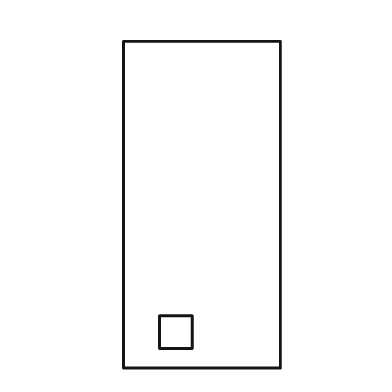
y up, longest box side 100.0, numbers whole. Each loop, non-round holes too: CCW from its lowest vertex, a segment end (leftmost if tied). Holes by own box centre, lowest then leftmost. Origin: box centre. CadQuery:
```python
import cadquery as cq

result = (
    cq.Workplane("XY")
    .moveTo(-24.0, -50.0)
    .lineTo(24.0, -50.0)
    .lineTo(24.0, 50.0)
    .lineTo(-24.0, 50.0)
    .close()
    .moveTo(-13.0, -44.0)
    .lineTo(-3.0, -44.0)
    .lineTo(-3.0, -34.0)
    .lineTo(-13.0, -34.0)
    .close()
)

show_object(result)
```